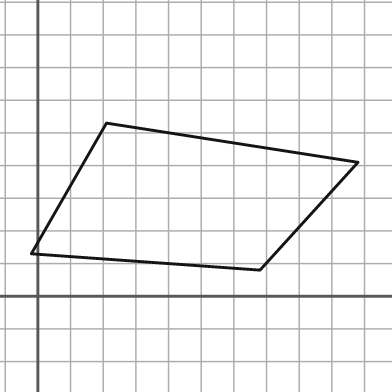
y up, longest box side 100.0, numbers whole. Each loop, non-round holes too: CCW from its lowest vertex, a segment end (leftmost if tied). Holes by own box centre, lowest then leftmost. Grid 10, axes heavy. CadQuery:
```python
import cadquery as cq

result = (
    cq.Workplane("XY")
    .moveTo(68.0, 8.0)
    .lineTo(98.0, 41.0)
    .lineTo(21.0, 53.0)
    .lineTo(-2.0, 13.0)
    .close()
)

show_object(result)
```